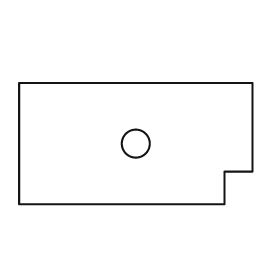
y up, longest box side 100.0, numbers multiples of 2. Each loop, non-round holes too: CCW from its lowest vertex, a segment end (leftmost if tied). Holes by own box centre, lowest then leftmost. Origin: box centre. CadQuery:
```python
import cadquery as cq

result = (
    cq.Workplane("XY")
    .moveTo(-50.0, -26.0)
    .lineTo(38.0, -26.0)
    .lineTo(38.0, -12.0)
    .lineTo(50.0, -12.0)
    .lineTo(50.0, 26.0)
    .lineTo(-50.0, 26.0)
    .close()
    .moveTo(0.0, 0.0)
    .circle(6.0)
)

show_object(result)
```